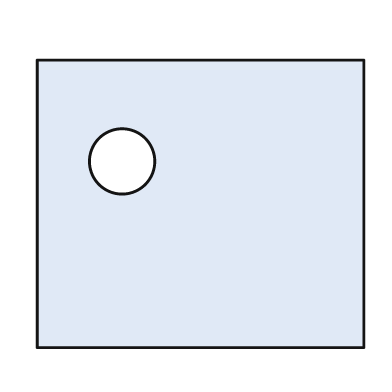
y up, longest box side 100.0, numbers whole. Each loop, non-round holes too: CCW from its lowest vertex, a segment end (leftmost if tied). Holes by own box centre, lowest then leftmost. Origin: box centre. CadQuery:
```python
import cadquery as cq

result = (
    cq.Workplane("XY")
    .moveTo(-50.0, -44.0)
    .lineTo(50.0, -44.0)
    .lineTo(50.0, 44.0)
    .lineTo(-50.0, 44.0)
    .close()
    .moveTo(-24.0, 13.0)
    .circle(10.0)
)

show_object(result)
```